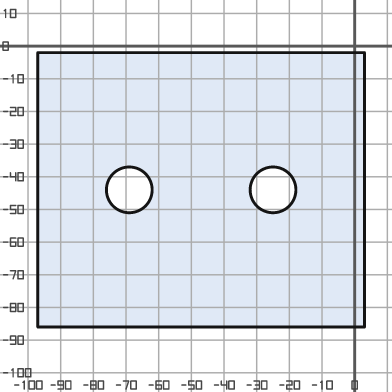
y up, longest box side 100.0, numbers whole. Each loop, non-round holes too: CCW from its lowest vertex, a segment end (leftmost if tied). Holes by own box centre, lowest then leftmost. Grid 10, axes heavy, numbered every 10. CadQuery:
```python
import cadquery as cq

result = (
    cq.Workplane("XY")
    .moveTo(-97.0, -86.0)
    .lineTo(3.0, -86.0)
    .lineTo(3.0, -2.0)
    .lineTo(-97.0, -2.0)
    .close()
    .moveTo(-69.0, -44.0)
    .circle(7.0)
    .moveTo(-25.0, -44.0)
    .circle(7.0)
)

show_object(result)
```